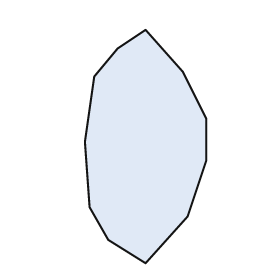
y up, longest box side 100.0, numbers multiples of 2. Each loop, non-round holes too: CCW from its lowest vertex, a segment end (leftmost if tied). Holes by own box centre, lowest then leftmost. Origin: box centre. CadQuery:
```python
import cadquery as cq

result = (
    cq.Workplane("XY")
    .moveTo(0.0, -50.0)
    .lineTo(18.0, -30.0)
    .lineTo(26.0, -6.0)
    .lineTo(26.0, 12.0)
    .lineTo(16.0, 32.0)
    .lineTo(0.0, 50.0)
    .lineTo(-12.0, 42.0)
    .lineTo(-22.0, 30.0)
    .lineTo(-26.0, 2.0)
    .lineTo(-24.0, -26.0)
    .lineTo(-16.0, -40.0)
    .close()
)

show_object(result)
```